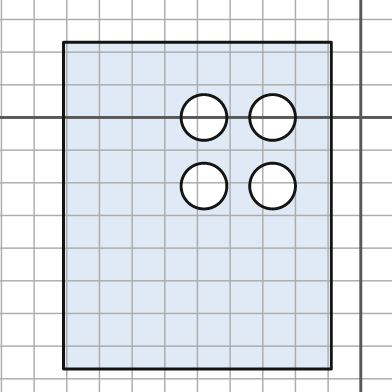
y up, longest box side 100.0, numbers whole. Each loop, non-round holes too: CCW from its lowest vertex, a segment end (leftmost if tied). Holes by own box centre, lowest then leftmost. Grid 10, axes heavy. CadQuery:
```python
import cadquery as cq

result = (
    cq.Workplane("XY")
    .moveTo(-91.0, -77.0)
    .lineTo(-9.0, -77.0)
    .lineTo(-9.0, 23.0)
    .lineTo(-91.0, 23.0)
    .close()
    .moveTo(-48.0, -21.0)
    .circle(7.0)
    .moveTo(-27.0, -21.0)
    .circle(7.0)
    .moveTo(-48.0, 0.0)
    .circle(7.0)
    .moveTo(-27.0, 0.0)
    .circle(7.0)
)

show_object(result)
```